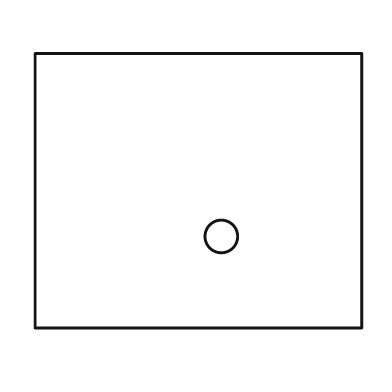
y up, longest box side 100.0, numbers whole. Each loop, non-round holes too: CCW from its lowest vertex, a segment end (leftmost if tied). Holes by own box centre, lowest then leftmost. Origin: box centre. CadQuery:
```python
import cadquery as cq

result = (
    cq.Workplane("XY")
    .moveTo(-50.0, -42.0)
    .lineTo(50.0, -42.0)
    .lineTo(50.0, 42.0)
    .lineTo(-50.0, 42.0)
    .close()
    .moveTo(7.0, -14.0)
    .circle(5.0)
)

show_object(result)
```